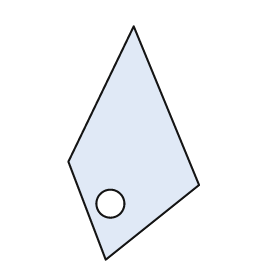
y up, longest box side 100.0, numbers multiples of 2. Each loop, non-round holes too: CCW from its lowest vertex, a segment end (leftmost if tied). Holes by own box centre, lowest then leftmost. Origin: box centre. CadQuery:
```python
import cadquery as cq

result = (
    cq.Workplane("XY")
    .moveTo(-12.0, -50.0)
    .lineTo(28.0, -18.0)
    .lineTo(0.0, 50.0)
    .lineTo(-28.0, -8.0)
    .close()
    .moveTo(-10.0, -26.0)
    .circle(6.0)
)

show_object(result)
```